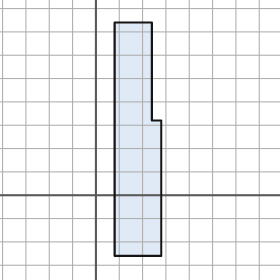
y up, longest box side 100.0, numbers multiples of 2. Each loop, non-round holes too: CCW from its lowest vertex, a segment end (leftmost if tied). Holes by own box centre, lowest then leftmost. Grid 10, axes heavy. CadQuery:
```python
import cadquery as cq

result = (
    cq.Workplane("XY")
    .moveTo(8.0, -26.0)
    .lineTo(28.0, -26.0)
    .lineTo(28.0, 32.0)
    .lineTo(24.0, 32.0)
    .lineTo(24.0, 74.0)
    .lineTo(8.0, 74.0)
    .close()
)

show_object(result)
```